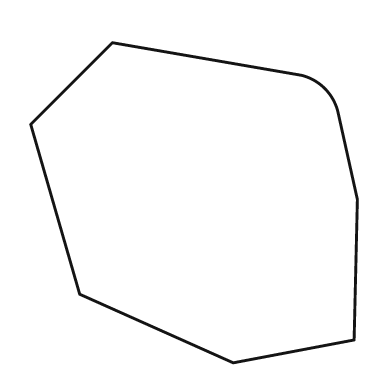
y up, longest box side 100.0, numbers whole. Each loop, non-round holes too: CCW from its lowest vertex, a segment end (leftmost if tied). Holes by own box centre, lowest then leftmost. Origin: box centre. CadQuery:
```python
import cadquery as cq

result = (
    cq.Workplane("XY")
    .moveTo(12.0, -49.0)
    .lineTo(49.0, -42.0)
    .lineTo(50.0, 1.0)
    .lineTo(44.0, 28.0)
    .threePointArc((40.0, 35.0), (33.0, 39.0))
    .lineTo(-25.0, 49.0)
    .lineTo(-50.0, 24.0)
    .lineTo(-35.0, -28.0)
    .close()
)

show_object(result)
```